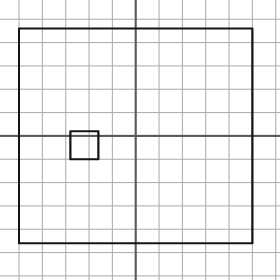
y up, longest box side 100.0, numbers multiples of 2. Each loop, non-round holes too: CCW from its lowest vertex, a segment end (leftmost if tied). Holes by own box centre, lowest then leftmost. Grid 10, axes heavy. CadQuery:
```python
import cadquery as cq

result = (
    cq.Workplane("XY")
    .moveTo(-50.0, -46.0)
    .lineTo(50.0, -46.0)
    .lineTo(50.0, 46.0)
    .lineTo(-50.0, 46.0)
    .close()
    .moveTo(-28.0, -10.0)
    .lineTo(-16.0, -10.0)
    .lineTo(-16.0, 2.0)
    .lineTo(-28.0, 2.0)
    .close()
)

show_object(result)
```